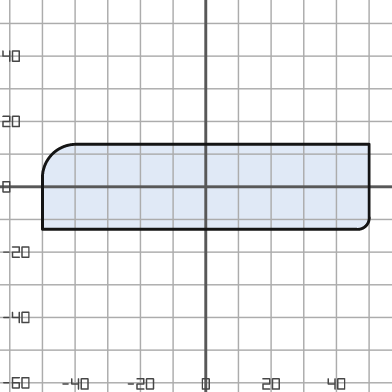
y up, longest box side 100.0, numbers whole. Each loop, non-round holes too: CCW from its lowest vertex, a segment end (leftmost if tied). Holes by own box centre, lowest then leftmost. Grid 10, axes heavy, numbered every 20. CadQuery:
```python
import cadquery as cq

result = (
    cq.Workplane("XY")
    .moveTo(-50.0, -13.0)
    .lineTo(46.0, -13.0)
    .threePointArc((49.0, -12.0), (50.0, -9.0))
    .lineTo(50.0, 13.0)
    .lineTo(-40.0, 13.0)
    .threePointArc((-47.0, 10.0), (-50.0, 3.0))
    .close()
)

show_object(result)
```